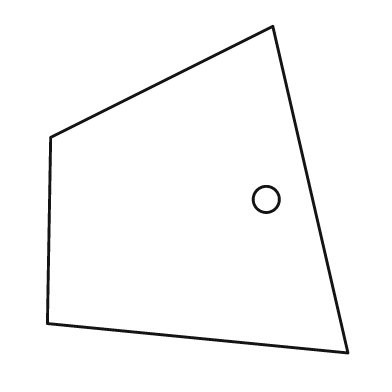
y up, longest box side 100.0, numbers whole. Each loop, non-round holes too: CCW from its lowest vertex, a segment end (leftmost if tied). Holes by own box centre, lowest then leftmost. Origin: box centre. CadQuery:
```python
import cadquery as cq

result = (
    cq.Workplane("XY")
    .moveTo(46.0, -50.0)
    .lineTo(23.0, 50.0)
    .lineTo(-45.0, 16.0)
    .lineTo(-46.0, -41.0)
    .close()
    .moveTo(21.0, -3.0)
    .circle(4.0)
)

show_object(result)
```